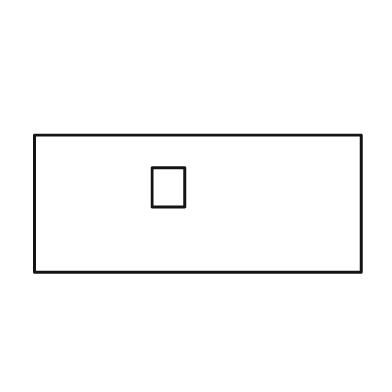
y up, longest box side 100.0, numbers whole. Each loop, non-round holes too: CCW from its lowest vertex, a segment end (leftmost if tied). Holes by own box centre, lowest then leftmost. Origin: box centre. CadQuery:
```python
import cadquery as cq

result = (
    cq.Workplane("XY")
    .moveTo(-50.0, -21.0)
    .lineTo(50.0, -21.0)
    .lineTo(50.0, 21.0)
    .lineTo(-50.0, 21.0)
    .close()
    .moveTo(-14.0, -1.0)
    .lineTo(-4.0, -1.0)
    .lineTo(-4.0, 11.0)
    .lineTo(-14.0, 11.0)
    .close()
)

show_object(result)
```